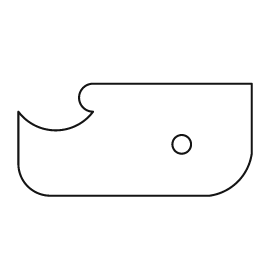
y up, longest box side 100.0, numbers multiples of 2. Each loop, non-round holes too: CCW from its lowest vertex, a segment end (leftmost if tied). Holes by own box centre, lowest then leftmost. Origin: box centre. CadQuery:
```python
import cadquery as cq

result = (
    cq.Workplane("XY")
    .moveTo(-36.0, -24.0)
    .lineTo(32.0, -24.0)
    .threePointArc((44.0, -18.0), (50.0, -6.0))
    .lineTo(50.0, 24.0)
    .lineTo(-18.0, 24.0)
    .threePointArc((-24.0, 18.0), (-18.0, 12.0))
    .threePointArc((-34.0, 4.0), (-50.0, 12.0))
    .lineTo(-50.0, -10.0)
    .threePointArc((-46.0, -20.0), (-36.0, -24.0))
    .close()
    .moveTo(20.0, -2.0)
    .circle(4.0)
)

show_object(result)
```